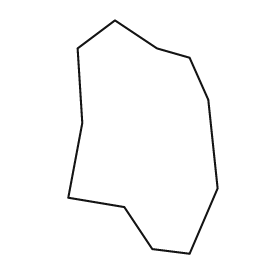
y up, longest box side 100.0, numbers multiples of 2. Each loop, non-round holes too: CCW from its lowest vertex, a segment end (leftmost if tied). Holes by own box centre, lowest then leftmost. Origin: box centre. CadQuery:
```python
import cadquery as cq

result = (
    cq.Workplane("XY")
    .moveTo(20.0, -50.0)
    .lineTo(32.0, -22.0)
    .lineTo(28.0, 16.0)
    .lineTo(20.0, 34.0)
    .lineTo(6.0, 38.0)
    .lineTo(-12.0, 50.0)
    .lineTo(-28.0, 38.0)
    .lineTo(-26.0, 6.0)
    .lineTo(-32.0, -26.0)
    .lineTo(-8.0, -30.0)
    .lineTo(4.0, -48.0)
    .close()
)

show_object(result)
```